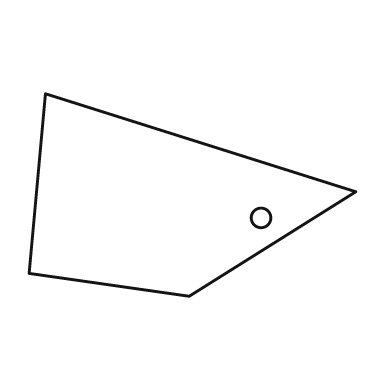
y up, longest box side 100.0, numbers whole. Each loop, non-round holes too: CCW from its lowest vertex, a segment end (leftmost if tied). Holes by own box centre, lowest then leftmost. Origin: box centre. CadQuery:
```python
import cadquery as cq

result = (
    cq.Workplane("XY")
    .moveTo(-1.0, -31.0)
    .lineTo(50.0, 1.0)
    .lineTo(-45.0, 31.0)
    .lineTo(-50.0, -24.0)
    .close()
    .moveTo(21.0, -7.0)
    .circle(3.0)
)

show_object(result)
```